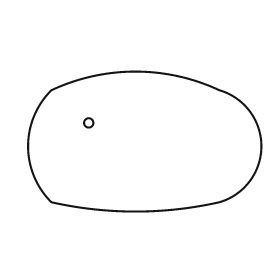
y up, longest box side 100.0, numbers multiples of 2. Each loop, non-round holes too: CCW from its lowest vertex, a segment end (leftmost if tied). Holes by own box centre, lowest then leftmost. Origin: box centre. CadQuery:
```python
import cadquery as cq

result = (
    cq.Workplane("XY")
    .moveTo(-40.0, -26.0)
    .threePointArc((-4.0, -30.0), (32.0, -26.0))
    .threePointArc((50.0, -2.0), (32.0, 22.0))
    .threePointArc((-4.0, 30.0), (-40.0, 22.0))
    .threePointArc((-50.0, -2.0), (-40.0, -26.0))
    .close()
    .moveTo(-24.0, 8.0)
    .circle(2.0)
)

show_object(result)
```